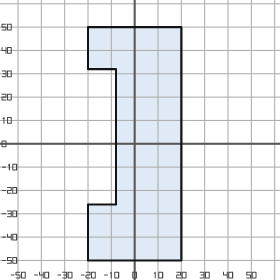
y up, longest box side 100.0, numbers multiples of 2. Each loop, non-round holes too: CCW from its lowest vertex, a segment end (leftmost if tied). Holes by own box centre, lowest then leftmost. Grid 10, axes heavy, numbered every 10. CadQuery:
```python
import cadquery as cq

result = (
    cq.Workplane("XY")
    .moveTo(-20.0, -50.0)
    .lineTo(20.0, -50.0)
    .lineTo(20.0, 50.0)
    .lineTo(-20.0, 50.0)
    .lineTo(-20.0, 32.0)
    .lineTo(-8.0, 32.0)
    .lineTo(-8.0, -26.0)
    .lineTo(-20.0, -26.0)
    .close()
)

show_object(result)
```